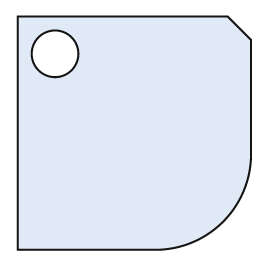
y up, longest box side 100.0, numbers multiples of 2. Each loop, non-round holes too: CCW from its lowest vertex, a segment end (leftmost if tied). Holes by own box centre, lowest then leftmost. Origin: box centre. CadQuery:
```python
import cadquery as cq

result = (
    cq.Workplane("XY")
    .moveTo(-50.0, -50.0)
    .lineTo(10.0, -50.0)
    .threePointArc((38.0, -38.0), (50.0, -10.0))
    .lineTo(50.0, 40.0)
    .lineTo(40.0, 50.0)
    .lineTo(-50.0, 50.0)
    .close()
    .moveTo(-34.0, 34.0)
    .circle(10.0)
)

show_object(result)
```